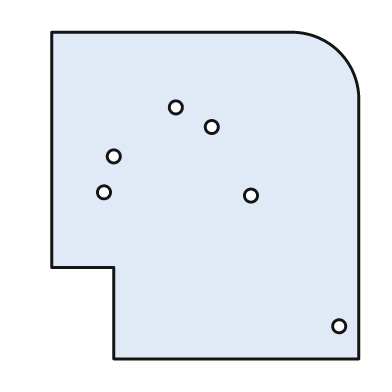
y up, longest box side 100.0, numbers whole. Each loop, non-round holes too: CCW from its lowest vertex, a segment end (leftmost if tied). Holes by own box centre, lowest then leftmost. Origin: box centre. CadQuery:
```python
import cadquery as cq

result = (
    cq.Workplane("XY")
    .moveTo(-28.0, -50.0)
    .lineTo(47.0, -50.0)
    .lineTo(47.0, 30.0)
    .threePointArc((41.0, 44.0), (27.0, 50.0))
    .lineTo(-47.0, 50.0)
    .lineTo(-47.0, -22.0)
    .lineTo(-28.0, -22.0)
    .close()
    .moveTo(41.0, -40.0)
    .circle(2.0)
    .moveTo(14.0, 0.0)
    .circle(2.0)
    .moveTo(-31.0, 1.0)
    .circle(2.0)
    .moveTo(-28.0, 12.0)
    .circle(2.0)
    .moveTo(2.0, 21.0)
    .circle(2.0)
    .moveTo(-9.0, 27.0)
    .circle(2.0)
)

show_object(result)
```